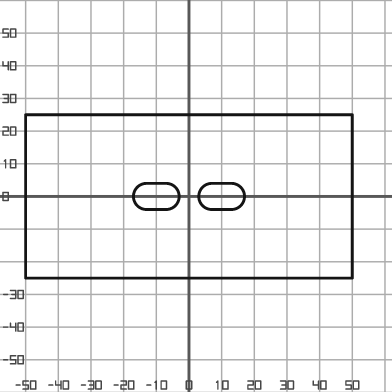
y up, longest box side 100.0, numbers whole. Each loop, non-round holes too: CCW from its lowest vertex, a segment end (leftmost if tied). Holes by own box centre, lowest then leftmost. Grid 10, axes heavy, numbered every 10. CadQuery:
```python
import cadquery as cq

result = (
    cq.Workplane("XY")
    .moveTo(-50.0, -25.0)
    .lineTo(50.0, -25.0)
    .lineTo(50.0, 25.0)
    .lineTo(-50.0, 25.0)
    .close()
    .moveTo(-13.0, -4.0)
    .lineTo(-7.0, -4.0)
    .threePointArc((-3.0, 0.0), (-7.0, 4.0))
    .lineTo(-13.0, 4.0)
    .threePointArc((-17.0, 0.0), (-13.0, -4.0))
    .close()
    .moveTo(7.0, -4.0)
    .lineTo(13.0, -4.0)
    .threePointArc((17.0, 0.0), (13.0, 4.0))
    .lineTo(7.0, 4.0)
    .threePointArc((3.0, 0.0), (7.0, -4.0))
    .close()
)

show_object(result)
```